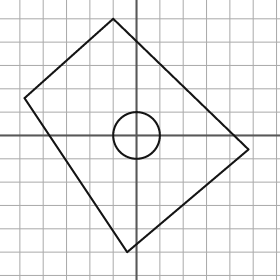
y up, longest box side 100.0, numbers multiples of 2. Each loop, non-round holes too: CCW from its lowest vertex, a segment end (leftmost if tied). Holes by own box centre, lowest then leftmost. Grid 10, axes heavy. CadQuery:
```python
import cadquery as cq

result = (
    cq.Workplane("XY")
    .moveTo(-4.0, -50.0)
    .lineTo(48.0, -6.0)
    .lineTo(-10.0, 50.0)
    .lineTo(-48.0, 16.0)
    .close()
    .moveTo(0.0, 0.0)
    .circle(10.0)
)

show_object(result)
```